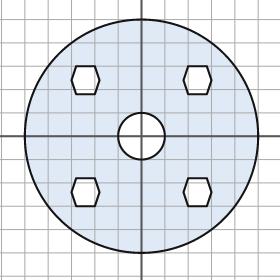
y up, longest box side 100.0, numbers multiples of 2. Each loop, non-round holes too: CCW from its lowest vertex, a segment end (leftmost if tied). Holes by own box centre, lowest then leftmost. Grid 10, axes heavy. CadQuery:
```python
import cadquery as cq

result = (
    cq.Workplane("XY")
    .moveTo(0.0, 0.0)
    .circle(50.0)
    .moveTo(-28.0, -30.0)
    .lineTo(-20.0, -30.0)
    .lineTo(-18.0, -24.0)
    .lineTo(-20.0, -18.0)
    .lineTo(-28.0, -18.0)
    .lineTo(-30.0, -24.0)
    .close()
    .moveTo(20.0, -30.0)
    .lineTo(28.0, -30.0)
    .lineTo(30.0, -24.0)
    .lineTo(28.0, -18.0)
    .lineTo(20.0, -18.0)
    .lineTo(18.0, -24.0)
    .close()
    .moveTo(0.0, 0.0)
    .circle(10.0)
    .moveTo(-28.0, 18.0)
    .lineTo(-20.0, 18.0)
    .lineTo(-18.0, 24.0)
    .lineTo(-20.0, 30.0)
    .lineTo(-28.0, 30.0)
    .lineTo(-30.0, 24.0)
    .close()
    .moveTo(20.0, 18.0)
    .lineTo(28.0, 18.0)
    .lineTo(30.0, 24.0)
    .lineTo(28.0, 30.0)
    .lineTo(20.0, 30.0)
    .lineTo(18.0, 24.0)
    .close()
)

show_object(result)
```